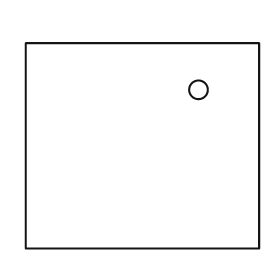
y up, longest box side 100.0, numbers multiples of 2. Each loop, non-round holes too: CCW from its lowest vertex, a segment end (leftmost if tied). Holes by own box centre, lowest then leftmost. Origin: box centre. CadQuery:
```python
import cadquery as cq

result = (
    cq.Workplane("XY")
    .moveTo(-50.0, -44.0)
    .lineTo(50.0, -44.0)
    .lineTo(50.0, 44.0)
    .lineTo(-50.0, 44.0)
    .close()
    .moveTo(24.0, 24.0)
    .circle(4.0)
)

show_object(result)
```